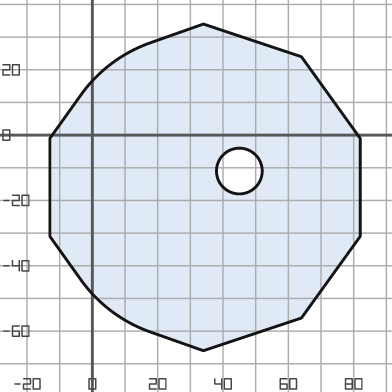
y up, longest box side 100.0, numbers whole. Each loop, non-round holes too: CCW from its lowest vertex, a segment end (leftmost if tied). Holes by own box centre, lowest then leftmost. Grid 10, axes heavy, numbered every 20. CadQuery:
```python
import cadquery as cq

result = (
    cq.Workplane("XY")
    .moveTo(34.0, -66.0)
    .lineTo(64.0, -56.0)
    .lineTo(82.0, -31.0)
    .lineTo(82.0, -1.0)
    .lineTo(64.0, 24.0)
    .lineTo(34.0, 34.0)
    .lineTo(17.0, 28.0)
    .threePointArc((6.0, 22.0), (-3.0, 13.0))
    .lineTo(-13.0, -1.0)
    .lineTo(-13.0, -31.0)
    .lineTo(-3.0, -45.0)
    .threePointArc((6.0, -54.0), (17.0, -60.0))
    .close()
    .moveTo(45.0, -11.0)
    .circle(7.0)
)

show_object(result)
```